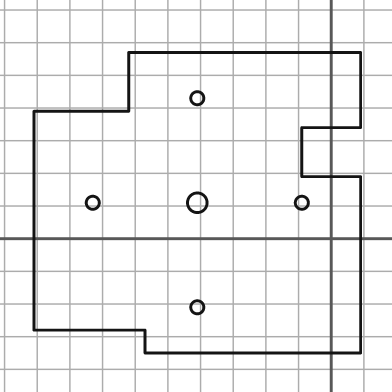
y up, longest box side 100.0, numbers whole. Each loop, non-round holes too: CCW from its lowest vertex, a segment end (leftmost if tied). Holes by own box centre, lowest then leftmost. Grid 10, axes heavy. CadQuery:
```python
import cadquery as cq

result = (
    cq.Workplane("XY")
    .moveTo(-57.0, -35.0)
    .lineTo(9.0, -35.0)
    .lineTo(9.0, 19.0)
    .lineTo(-9.0, 19.0)
    .lineTo(-9.0, 34.0)
    .lineTo(9.0, 34.0)
    .lineTo(9.0, 57.0)
    .lineTo(-62.0, 57.0)
    .lineTo(-62.0, 39.0)
    .lineTo(-91.0, 39.0)
    .lineTo(-91.0, -28.0)
    .lineTo(-57.0, -28.0)
    .close()
    .moveTo(-41.0, -21.0)
    .circle(2.0)
    .moveTo(-73.0, 11.0)
    .circle(2.0)
    .moveTo(-41.0, 11.0)
    .circle(3.0)
    .moveTo(-9.0, 11.0)
    .circle(2.0)
    .moveTo(-41.0, 43.0)
    .circle(2.0)
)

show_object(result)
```